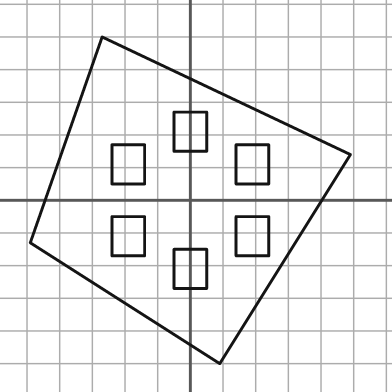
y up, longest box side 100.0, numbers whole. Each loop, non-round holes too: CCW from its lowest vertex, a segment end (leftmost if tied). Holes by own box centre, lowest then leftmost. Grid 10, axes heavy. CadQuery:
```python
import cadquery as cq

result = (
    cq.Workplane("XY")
    .moveTo(9.0, -50.0)
    .lineTo(49.0, 14.0)
    .lineTo(-27.0, 50.0)
    .lineTo(-49.0, -13.0)
    .close()
    .moveTo(-5.0, -27.0)
    .lineTo(5.0, -27.0)
    .lineTo(5.0, -15.0)
    .lineTo(-5.0, -15.0)
    .close()
    .moveTo(-24.0, -17.0)
    .lineTo(-14.0, -17.0)
    .lineTo(-14.0, -5.0)
    .lineTo(-24.0, -5.0)
    .close()
    .moveTo(14.0, -17.0)
    .lineTo(24.0, -17.0)
    .lineTo(24.0, -5.0)
    .lineTo(14.0, -5.0)
    .close()
    .moveTo(-24.0, 5.0)
    .lineTo(-14.0, 5.0)
    .lineTo(-14.0, 17.0)
    .lineTo(-24.0, 17.0)
    .close()
    .moveTo(14.0, 5.0)
    .lineTo(24.0, 5.0)
    .lineTo(24.0, 17.0)
    .lineTo(14.0, 17.0)
    .close()
    .moveTo(-5.0, 15.0)
    .lineTo(5.0, 15.0)
    .lineTo(5.0, 27.0)
    .lineTo(-5.0, 27.0)
    .close()
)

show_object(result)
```